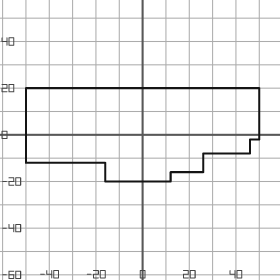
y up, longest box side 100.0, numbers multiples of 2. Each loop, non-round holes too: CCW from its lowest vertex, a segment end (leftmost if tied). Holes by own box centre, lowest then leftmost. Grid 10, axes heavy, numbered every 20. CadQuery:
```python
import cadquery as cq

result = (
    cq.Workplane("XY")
    .moveTo(-16.0, -20.0)
    .lineTo(12.0, -20.0)
    .lineTo(12.0, -16.0)
    .lineTo(26.0, -16.0)
    .lineTo(26.0, -8.0)
    .lineTo(46.0, -8.0)
    .lineTo(46.0, -2.0)
    .lineTo(50.0, -2.0)
    .lineTo(50.0, 20.0)
    .lineTo(-50.0, 20.0)
    .lineTo(-50.0, -12.0)
    .lineTo(-16.0, -12.0)
    .close()
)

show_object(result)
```